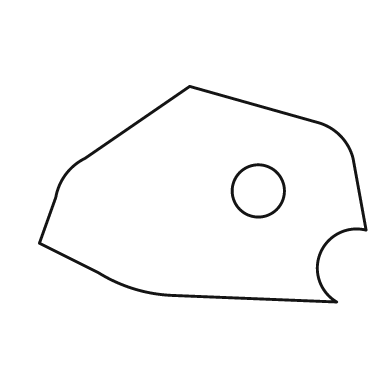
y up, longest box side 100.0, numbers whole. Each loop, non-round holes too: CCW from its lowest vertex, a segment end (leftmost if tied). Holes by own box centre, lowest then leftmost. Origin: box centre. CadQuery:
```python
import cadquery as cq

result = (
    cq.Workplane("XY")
    .moveTo(41.0, -33.0)
    .threePointArc((36.0, -18.0), (50.0, -11.0))
    .lineTo(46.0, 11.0)
    .threePointArc((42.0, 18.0), (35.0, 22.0))
    .lineTo(-4.0, 33.0)
    .lineTo(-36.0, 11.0)
    .threePointArc((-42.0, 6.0), (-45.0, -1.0))
    .lineTo(-50.0, -15.0)
    .lineTo(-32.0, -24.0)
    .threePointArc((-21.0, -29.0), (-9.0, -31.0))
    .close()
    .moveTo(17.0, 1.0)
    .circle(8.0)
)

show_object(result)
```